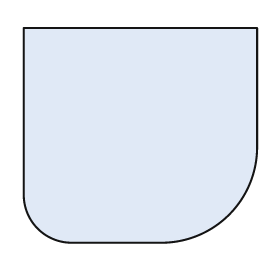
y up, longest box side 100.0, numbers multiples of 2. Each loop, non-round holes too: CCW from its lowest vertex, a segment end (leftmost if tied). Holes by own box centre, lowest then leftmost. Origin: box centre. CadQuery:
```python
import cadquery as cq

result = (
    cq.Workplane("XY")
    .moveTo(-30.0, -46.0)
    .lineTo(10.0, -46.0)
    .threePointArc((38.0, -34.0), (50.0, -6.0))
    .lineTo(50.0, 46.0)
    .lineTo(-50.0, 46.0)
    .lineTo(-50.0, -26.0)
    .threePointArc((-44.0, -40.0), (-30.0, -46.0))
    .close()
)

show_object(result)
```